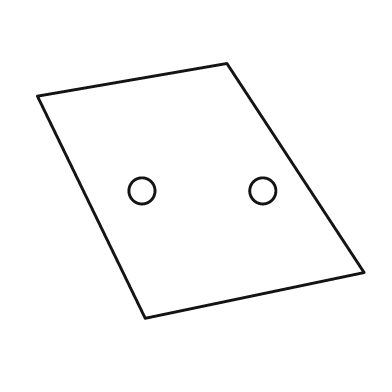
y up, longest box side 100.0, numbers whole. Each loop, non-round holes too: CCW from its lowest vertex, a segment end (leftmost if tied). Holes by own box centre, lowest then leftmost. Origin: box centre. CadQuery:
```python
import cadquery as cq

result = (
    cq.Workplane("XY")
    .moveTo(-17.0, -39.0)
    .lineTo(50.0, -25.0)
    .lineTo(8.0, 39.0)
    .lineTo(-50.0, 29.0)
    .close()
    .moveTo(-18.0, 0.0)
    .circle(4.0)
    .moveTo(19.0, 0.0)
    .circle(4.0)
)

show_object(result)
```